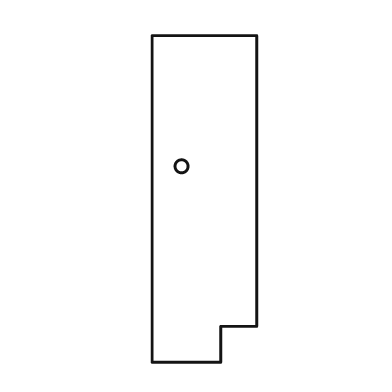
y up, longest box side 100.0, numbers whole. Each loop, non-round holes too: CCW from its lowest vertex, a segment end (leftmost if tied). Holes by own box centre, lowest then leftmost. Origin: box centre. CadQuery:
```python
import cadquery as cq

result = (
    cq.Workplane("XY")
    .moveTo(-16.0, -50.0)
    .lineTo(5.0, -50.0)
    .lineTo(5.0, -39.0)
    .lineTo(16.0, -39.0)
    .lineTo(16.0, 50.0)
    .lineTo(-16.0, 50.0)
    .close()
    .moveTo(-7.0, 10.0)
    .circle(2.0)
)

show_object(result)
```